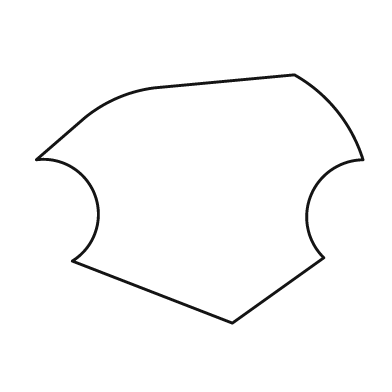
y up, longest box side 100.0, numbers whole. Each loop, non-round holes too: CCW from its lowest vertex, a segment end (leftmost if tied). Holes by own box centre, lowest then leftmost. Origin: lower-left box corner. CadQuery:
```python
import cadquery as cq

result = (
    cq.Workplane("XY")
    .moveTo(60.0, 0.0)
    .lineTo(88.0, 20.0)
    .threePointArc((84.0, 39.0), (100.0, 50.0))
    .threePointArc((92.0, 65.0), (79.0, 76.0))
    .lineTo(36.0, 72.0)
    .threePointArc((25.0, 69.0), (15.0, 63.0))
    .lineTo(0.0, 50.0)
    .threePointArc((18.0, 39.0), (11.0, 19.0))
    .close()
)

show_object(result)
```